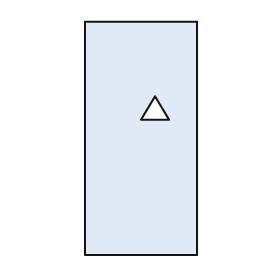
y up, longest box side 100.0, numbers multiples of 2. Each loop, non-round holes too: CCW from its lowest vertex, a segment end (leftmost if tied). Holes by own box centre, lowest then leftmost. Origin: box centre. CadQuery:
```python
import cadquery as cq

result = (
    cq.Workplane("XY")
    .moveTo(-24.0, -50.0)
    .lineTo(24.0, -50.0)
    .lineTo(24.0, 50.0)
    .lineTo(-24.0, 50.0)
    .close()
    .moveTo(0.0, 8.0)
    .lineTo(12.0, 8.0)
    .lineTo(6.0, 18.0)
    .close()
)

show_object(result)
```